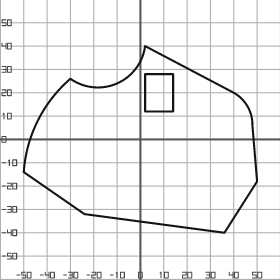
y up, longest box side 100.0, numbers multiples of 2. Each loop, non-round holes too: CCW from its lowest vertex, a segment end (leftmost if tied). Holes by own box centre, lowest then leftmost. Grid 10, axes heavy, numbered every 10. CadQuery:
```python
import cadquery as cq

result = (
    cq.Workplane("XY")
    .moveTo(36.0, -40.0)
    .lineTo(50.0, -18.0)
    .lineTo(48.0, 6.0)
    .threePointArc((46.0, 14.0), (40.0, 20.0))
    .lineTo(2.0, 40.0)
    .threePointArc((-10.0, 24.0), (-30.0, 26.0))
    .threePointArc((-44.0, 8.0), (-50.0, -14.0))
    .lineTo(-24.0, -32.0)
    .close()
    .moveTo(2.0, 12.0)
    .lineTo(14.0, 12.0)
    .lineTo(14.0, 28.0)
    .lineTo(2.0, 28.0)
    .close()
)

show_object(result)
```